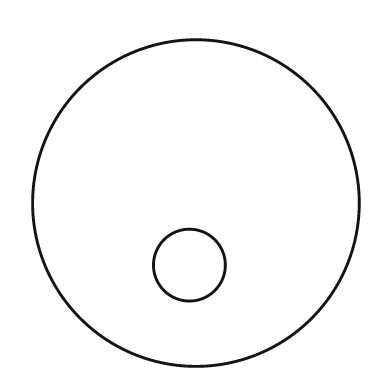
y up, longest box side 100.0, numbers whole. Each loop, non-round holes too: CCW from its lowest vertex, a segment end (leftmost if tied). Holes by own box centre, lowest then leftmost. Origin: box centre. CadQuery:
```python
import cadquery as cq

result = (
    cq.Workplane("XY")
    .moveTo(0.0, 0.0)
    .circle(50.0)
    .moveTo(-2.0, -19.0)
    .circle(11.0)
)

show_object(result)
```